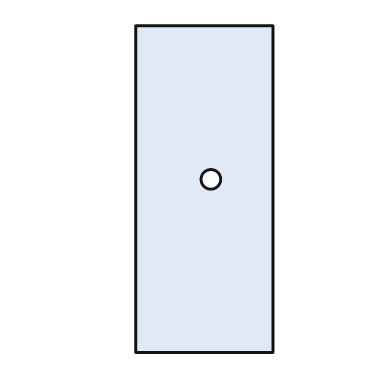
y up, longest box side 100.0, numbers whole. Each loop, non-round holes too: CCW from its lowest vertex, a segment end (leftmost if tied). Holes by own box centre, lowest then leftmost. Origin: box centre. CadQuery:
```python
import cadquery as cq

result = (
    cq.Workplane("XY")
    .moveTo(-21.0, -50.0)
    .lineTo(21.0, -50.0)
    .lineTo(21.0, 50.0)
    .lineTo(-21.0, 50.0)
    .close()
    .moveTo(2.0, 3.0)
    .circle(3.0)
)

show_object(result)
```